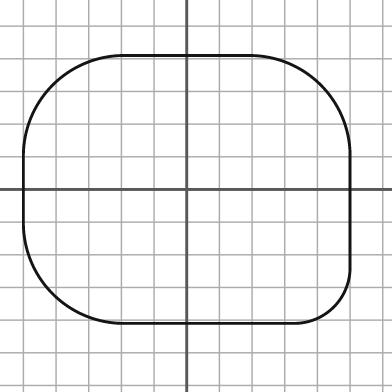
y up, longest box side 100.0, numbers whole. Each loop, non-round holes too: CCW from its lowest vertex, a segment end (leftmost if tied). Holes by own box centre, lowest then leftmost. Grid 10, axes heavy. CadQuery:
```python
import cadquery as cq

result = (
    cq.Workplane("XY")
    .moveTo(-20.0, -41.0)
    .lineTo(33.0, -41.0)
    .threePointArc((45.0, -36.0), (50.0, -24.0))
    .lineTo(50.0, 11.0)
    .threePointArc((41.0, 32.0), (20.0, 41.0))
    .lineTo(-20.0, 41.0)
    .threePointArc((-41.0, 32.0), (-50.0, 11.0))
    .lineTo(-50.0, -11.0)
    .threePointArc((-41.0, -32.0), (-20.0, -41.0))
    .close()
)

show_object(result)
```